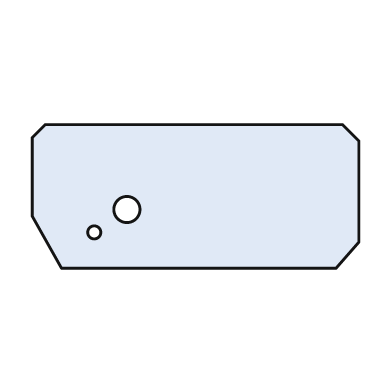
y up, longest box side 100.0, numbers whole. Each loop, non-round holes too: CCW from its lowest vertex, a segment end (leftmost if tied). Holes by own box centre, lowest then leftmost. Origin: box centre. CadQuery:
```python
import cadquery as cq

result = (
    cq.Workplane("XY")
    .moveTo(-41.0, -22.0)
    .lineTo(43.0, -22.0)
    .lineTo(50.0, -14.0)
    .lineTo(50.0, 17.0)
    .lineTo(45.0, 22.0)
    .lineTo(-46.0, 22.0)
    .lineTo(-50.0, 18.0)
    .lineTo(-50.0, -6.0)
    .close()
    .moveTo(-31.0, -11.0)
    .circle(2.0)
    .moveTo(-21.0, -4.0)
    .circle(4.0)
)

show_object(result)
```